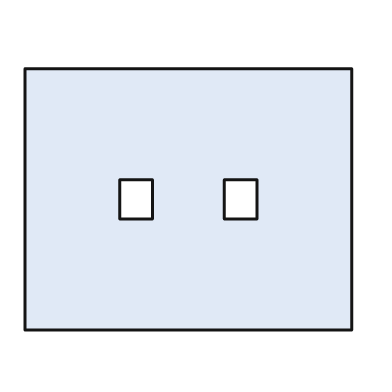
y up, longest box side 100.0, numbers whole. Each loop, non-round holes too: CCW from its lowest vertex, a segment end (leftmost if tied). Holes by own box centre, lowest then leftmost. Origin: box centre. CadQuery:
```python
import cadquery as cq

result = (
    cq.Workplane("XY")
    .moveTo(-50.0, -40.0)
    .lineTo(50.0, -40.0)
    .lineTo(50.0, 40.0)
    .lineTo(-50.0, 40.0)
    .close()
    .moveTo(-21.0, -6.0)
    .lineTo(-11.0, -6.0)
    .lineTo(-11.0, 6.0)
    .lineTo(-21.0, 6.0)
    .close()
    .moveTo(11.0, -6.0)
    .lineTo(21.0, -6.0)
    .lineTo(21.0, 6.0)
    .lineTo(11.0, 6.0)
    .close()
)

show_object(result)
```